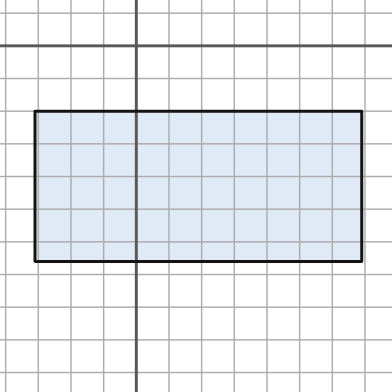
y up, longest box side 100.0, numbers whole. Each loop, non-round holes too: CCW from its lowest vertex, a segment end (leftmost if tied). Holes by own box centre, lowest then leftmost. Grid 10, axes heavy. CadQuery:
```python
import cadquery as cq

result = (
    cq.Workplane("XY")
    .moveTo(-31.0, -66.0)
    .lineTo(69.0, -66.0)
    .lineTo(69.0, -20.0)
    .lineTo(-31.0, -20.0)
    .close()
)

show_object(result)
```